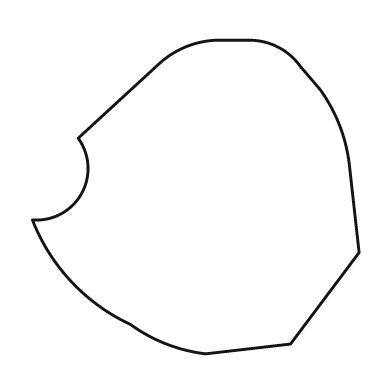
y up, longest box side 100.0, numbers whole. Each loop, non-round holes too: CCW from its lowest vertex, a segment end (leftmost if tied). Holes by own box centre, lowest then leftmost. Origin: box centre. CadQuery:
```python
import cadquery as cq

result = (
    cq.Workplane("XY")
    .moveTo(3.0, -48.0)
    .lineTo(29.0, -45.0)
    .lineTo(50.0, -17.0)
    .lineTo(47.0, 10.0)
    .threePointArc((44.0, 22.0), (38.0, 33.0))
    .lineTo(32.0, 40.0)
    .threePointArc((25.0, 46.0), (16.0, 48.0))
    .lineTo(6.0, 48.0)
    .threePointArc((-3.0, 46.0), (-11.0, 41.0))
    .lineTo(-36.0, 18.0)
    .threePointArc((-35.0, 1.0), (-50.0, -7.0))
    .threePointArc((-38.0, -26.0), (-20.0, -39.0))
    .threePointArc((-9.0, -45.0), (3.0, -48.0))
    .close()
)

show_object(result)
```